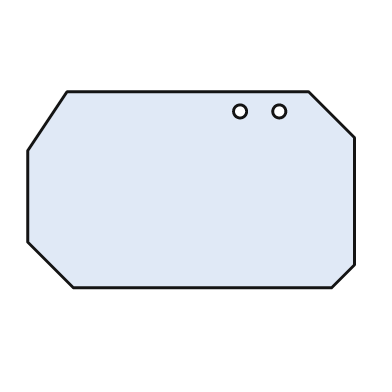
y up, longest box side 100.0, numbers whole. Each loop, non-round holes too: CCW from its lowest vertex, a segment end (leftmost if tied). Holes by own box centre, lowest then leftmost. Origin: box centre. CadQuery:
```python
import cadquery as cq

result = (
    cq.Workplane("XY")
    .moveTo(-36.0, -30.0)
    .lineTo(43.0, -30.0)
    .lineTo(50.0, -23.0)
    .lineTo(50.0, 16.0)
    .lineTo(36.0, 30.0)
    .lineTo(-38.0, 30.0)
    .lineTo(-50.0, 12.0)
    .lineTo(-50.0, -16.0)
    .close()
    .moveTo(15.0, 24.0)
    .circle(2.0)
    .moveTo(27.0, 24.0)
    .circle(2.0)
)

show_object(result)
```